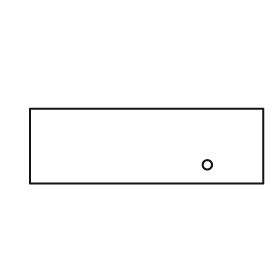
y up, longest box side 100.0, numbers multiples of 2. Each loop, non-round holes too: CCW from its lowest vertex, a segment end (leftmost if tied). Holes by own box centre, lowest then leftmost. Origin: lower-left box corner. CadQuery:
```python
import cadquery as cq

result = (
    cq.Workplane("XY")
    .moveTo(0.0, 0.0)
    .lineTo(100.0, 0.0)
    .lineTo(100.0, 32.0)
    .lineTo(0.0, 32.0)
    .close()
    .moveTo(76.0, 8.0)
    .circle(2.0)
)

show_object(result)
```